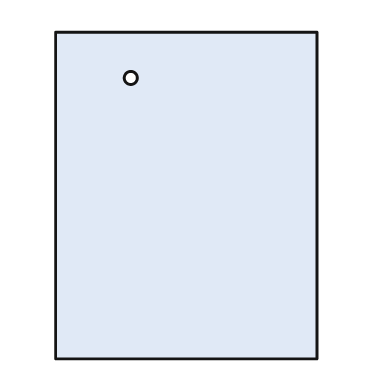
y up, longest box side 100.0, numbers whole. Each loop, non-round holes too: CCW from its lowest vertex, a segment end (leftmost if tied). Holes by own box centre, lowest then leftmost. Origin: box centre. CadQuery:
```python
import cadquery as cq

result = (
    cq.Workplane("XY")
    .moveTo(-40.0, -50.0)
    .lineTo(40.0, -50.0)
    .lineTo(40.0, 50.0)
    .lineTo(-40.0, 50.0)
    .close()
    .moveTo(-17.0, 36.0)
    .circle(2.0)
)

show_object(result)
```